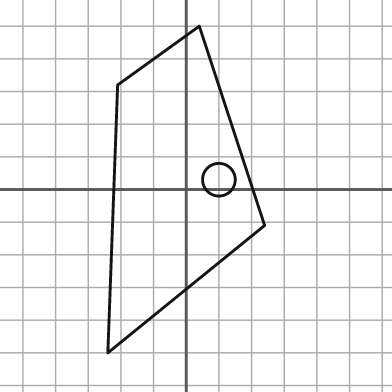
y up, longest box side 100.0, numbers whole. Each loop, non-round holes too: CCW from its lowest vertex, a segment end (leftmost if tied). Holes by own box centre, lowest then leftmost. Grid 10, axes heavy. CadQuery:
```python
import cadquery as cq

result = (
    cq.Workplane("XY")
    .moveTo(-24.0, -50.0)
    .lineTo(24.0, -11.0)
    .lineTo(4.0, 50.0)
    .lineTo(-21.0, 32.0)
    .close()
    .moveTo(10.0, 3.0)
    .circle(5.0)
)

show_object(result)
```